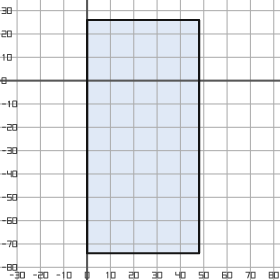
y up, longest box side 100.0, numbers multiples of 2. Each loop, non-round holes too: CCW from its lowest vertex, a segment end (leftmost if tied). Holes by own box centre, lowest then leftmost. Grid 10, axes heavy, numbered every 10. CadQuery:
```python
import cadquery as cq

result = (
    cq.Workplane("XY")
    .moveTo(0.0, -74.0)
    .lineTo(48.0, -74.0)
    .lineTo(48.0, 26.0)
    .lineTo(0.0, 26.0)
    .close()
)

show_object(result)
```